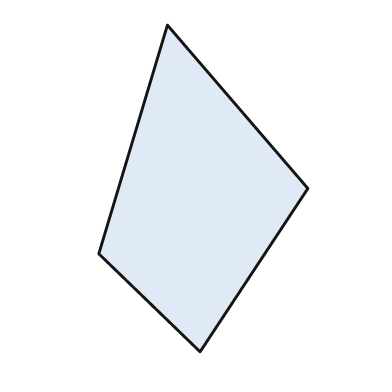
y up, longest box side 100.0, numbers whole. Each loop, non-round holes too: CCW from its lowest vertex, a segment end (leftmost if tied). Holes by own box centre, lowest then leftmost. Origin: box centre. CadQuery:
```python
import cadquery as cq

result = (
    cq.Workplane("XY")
    .moveTo(-1.0, -50.0)
    .lineTo(32.0, 0.0)
    .lineTo(-11.0, 50.0)
    .lineTo(-32.0, -20.0)
    .close()
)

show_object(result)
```